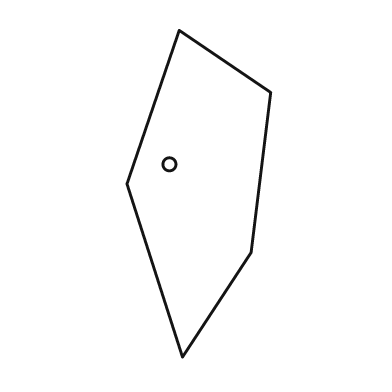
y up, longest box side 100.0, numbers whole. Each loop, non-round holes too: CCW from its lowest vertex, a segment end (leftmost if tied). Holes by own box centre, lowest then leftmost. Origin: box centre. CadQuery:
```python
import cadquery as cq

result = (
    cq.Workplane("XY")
    .moveTo(-5.0, -50.0)
    .lineTo(16.0, -18.0)
    .lineTo(22.0, 31.0)
    .lineTo(-6.0, 50.0)
    .lineTo(-22.0, 3.0)
    .close()
    .moveTo(-9.0, 9.0)
    .circle(2.0)
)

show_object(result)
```